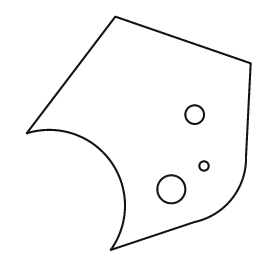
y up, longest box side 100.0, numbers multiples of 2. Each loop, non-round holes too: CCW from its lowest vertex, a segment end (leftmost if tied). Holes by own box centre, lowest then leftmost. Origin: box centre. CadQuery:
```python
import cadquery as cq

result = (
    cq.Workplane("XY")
    .moveTo(-12.0, -50.0)
    .lineTo(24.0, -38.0)
    .threePointArc((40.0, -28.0), (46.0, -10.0))
    .lineTo(48.0, 30.0)
    .lineTo(-10.0, 50.0)
    .lineTo(-48.0, 0.0)
    .threePointArc((-12.0, -12.0), (-12.0, -50.0))
    .close()
    .moveTo(14.0, -24.0)
    .circle(6.0)
    .moveTo(28.0, -14.0)
    .circle(2.0)
    .moveTo(24.0, 8.0)
    .circle(4.0)
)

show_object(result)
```